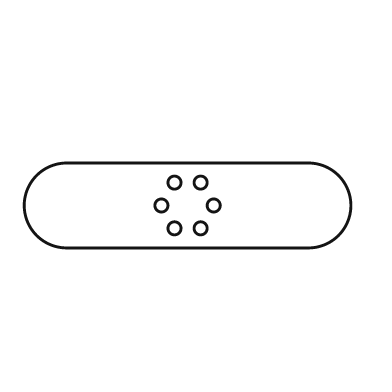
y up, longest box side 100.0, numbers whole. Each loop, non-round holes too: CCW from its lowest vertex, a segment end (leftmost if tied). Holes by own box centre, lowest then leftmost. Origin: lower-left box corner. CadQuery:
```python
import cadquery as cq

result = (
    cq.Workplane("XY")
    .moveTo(13.0, 0.0)
    .lineTo(87.0, 0.0)
    .threePointArc((100.0, 13.0), (87.0, 26.0))
    .lineTo(13.0, 26.0)
    .threePointArc((0.0, 13.0), (13.0, 0.0))
    .close()
    .moveTo(46.0, 6.0)
    .circle(2.0)
    .moveTo(54.0, 6.0)
    .circle(2.0)
    .moveTo(42.0, 13.0)
    .circle(2.0)
    .moveTo(58.0, 13.0)
    .circle(2.0)
    .moveTo(46.0, 20.0)
    .circle(2.0)
    .moveTo(54.0, 20.0)
    .circle(2.0)
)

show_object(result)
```